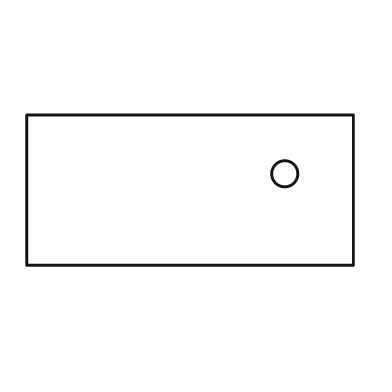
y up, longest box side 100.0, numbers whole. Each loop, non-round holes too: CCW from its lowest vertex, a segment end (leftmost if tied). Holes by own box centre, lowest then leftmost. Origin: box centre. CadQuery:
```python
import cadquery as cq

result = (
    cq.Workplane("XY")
    .moveTo(-50.0, -23.0)
    .lineTo(50.0, -23.0)
    .lineTo(50.0, 23.0)
    .lineTo(-50.0, 23.0)
    .close()
    .moveTo(29.0, 5.0)
    .circle(4.0)
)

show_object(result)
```